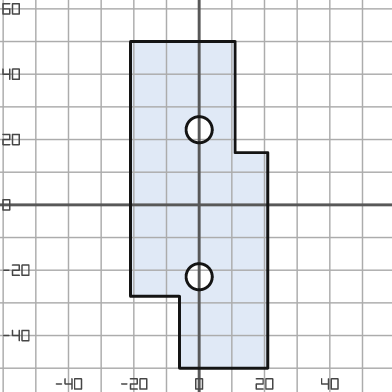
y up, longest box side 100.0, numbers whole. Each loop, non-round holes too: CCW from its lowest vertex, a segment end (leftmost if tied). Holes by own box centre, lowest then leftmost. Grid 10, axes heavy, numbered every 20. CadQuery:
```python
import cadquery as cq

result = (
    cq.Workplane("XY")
    .moveTo(-6.0, -50.0)
    .lineTo(21.0, -50.0)
    .lineTo(21.0, 16.0)
    .lineTo(11.0, 16.0)
    .lineTo(11.0, 50.0)
    .lineTo(-21.0, 50.0)
    .lineTo(-21.0, -28.0)
    .lineTo(-6.0, -28.0)
    .close()
    .moveTo(0.0, -22.0)
    .circle(4.0)
    .moveTo(0.0, 23.0)
    .circle(4.0)
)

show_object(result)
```